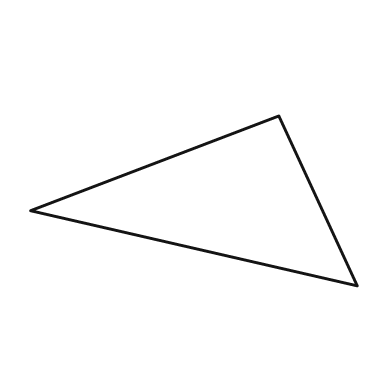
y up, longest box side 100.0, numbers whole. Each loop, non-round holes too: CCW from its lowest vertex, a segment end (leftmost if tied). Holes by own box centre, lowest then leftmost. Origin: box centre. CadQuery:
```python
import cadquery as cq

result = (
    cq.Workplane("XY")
    .moveTo(50.0, -26.0)
    .lineTo(26.0, 26.0)
    .lineTo(-50.0, -3.0)
    .close()
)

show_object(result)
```